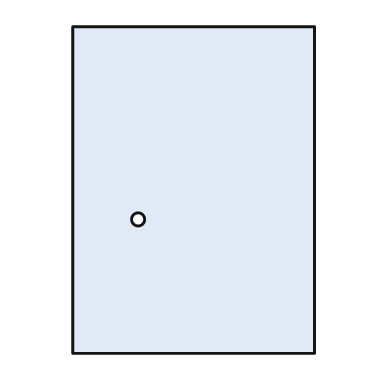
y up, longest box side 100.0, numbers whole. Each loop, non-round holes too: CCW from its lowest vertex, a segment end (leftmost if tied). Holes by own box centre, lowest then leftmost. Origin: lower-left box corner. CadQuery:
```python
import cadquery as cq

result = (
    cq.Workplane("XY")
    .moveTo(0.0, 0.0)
    .lineTo(74.0, 0.0)
    .lineTo(74.0, 100.0)
    .lineTo(0.0, 100.0)
    .close()
    .moveTo(20.0, 41.0)
    .circle(2.0)
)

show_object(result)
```